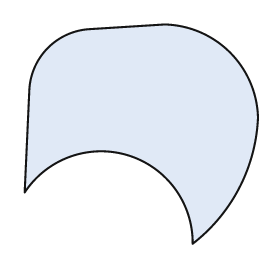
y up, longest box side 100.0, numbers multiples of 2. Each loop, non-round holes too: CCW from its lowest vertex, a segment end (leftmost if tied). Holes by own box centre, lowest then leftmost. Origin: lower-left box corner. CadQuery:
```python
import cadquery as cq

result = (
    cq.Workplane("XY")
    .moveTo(72.0, 0.0)
    .threePointArc((92.0, 24.0), (100.0, 54.0))
    .threePointArc((88.0, 82.0), (60.0, 94.0))
    .lineTo(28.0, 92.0)
    .threePointArc((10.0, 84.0), (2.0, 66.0))
    .lineTo(0.0, 22.0)
    .threePointArc((44.0, 38.0), (72.0, 0.0))
    .close()
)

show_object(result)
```